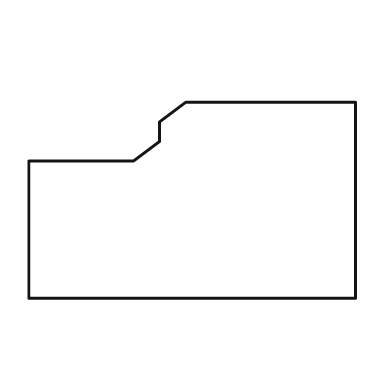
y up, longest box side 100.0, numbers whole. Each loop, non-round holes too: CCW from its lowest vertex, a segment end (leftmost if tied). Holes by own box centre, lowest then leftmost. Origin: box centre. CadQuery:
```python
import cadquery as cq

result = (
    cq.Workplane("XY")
    .moveTo(-50.0, -30.0)
    .lineTo(50.0, -30.0)
    .lineTo(50.0, 30.0)
    .lineTo(-2.0, 30.0)
    .lineTo(-10.0, 24.0)
    .lineTo(-10.0, 18.0)
    .lineTo(-18.0, 12.0)
    .lineTo(-50.0, 12.0)
    .close()
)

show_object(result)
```